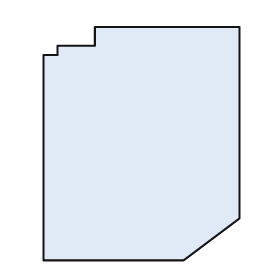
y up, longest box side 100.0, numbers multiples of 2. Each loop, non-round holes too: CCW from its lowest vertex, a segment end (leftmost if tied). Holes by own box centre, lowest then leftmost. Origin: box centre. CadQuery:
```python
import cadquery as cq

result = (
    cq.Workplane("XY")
    .moveTo(-42.0, -50.0)
    .lineTo(18.0, -50.0)
    .lineTo(42.0, -32.0)
    .lineTo(42.0, 50.0)
    .lineTo(-20.0, 50.0)
    .lineTo(-20.0, 42.0)
    .lineTo(-36.0, 42.0)
    .lineTo(-36.0, 38.0)
    .lineTo(-42.0, 38.0)
    .close()
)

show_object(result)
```